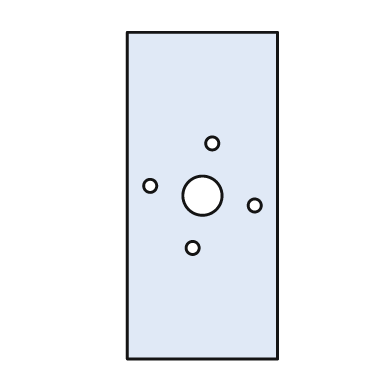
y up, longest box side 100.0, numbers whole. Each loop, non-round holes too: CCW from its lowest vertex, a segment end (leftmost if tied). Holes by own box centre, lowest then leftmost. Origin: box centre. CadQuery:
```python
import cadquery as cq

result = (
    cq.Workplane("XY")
    .moveTo(-23.0, -50.0)
    .lineTo(23.0, -50.0)
    .lineTo(23.0, 50.0)
    .lineTo(-23.0, 50.0)
    .close()
    .moveTo(-3.0, -16.0)
    .circle(2.0)
    .moveTo(16.0, -3.0)
    .circle(2.0)
    .moveTo(0.0, 0.0)
    .circle(6.0)
    .moveTo(-16.0, 3.0)
    .circle(2.0)
    .moveTo(3.0, 16.0)
    .circle(2.0)
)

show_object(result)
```